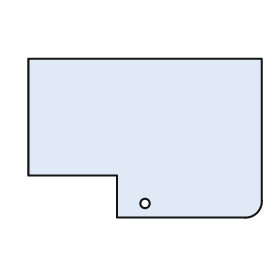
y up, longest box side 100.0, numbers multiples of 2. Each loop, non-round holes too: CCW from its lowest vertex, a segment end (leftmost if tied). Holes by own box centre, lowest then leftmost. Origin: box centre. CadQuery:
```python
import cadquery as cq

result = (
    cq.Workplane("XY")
    .moveTo(-12.0, -34.0)
    .lineTo(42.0, -34.0)
    .threePointArc((48.0, -32.0), (50.0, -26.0))
    .lineTo(50.0, 34.0)
    .lineTo(-50.0, 34.0)
    .lineTo(-50.0, -16.0)
    .lineTo(-12.0, -16.0)
    .close()
    .moveTo(0.0, -28.0)
    .circle(2.0)
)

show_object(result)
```